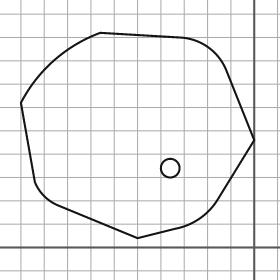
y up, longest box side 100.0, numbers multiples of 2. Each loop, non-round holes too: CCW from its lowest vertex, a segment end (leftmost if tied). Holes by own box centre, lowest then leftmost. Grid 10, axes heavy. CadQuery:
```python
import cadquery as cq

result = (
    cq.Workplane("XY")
    .moveTo(-50.0, 4.0)
    .lineTo(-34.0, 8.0)
    .threePointArc((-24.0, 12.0), (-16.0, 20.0))
    .lineTo(0.0, 46.0)
    .lineTo(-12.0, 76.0)
    .threePointArc((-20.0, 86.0), (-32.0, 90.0))
    .lineTo(-66.0, 92.0)
    .threePointArc((-86.0, 80.0), (-100.0, 62.0))
    .lineTo(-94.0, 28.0)
    .threePointArc((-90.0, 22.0), (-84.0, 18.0))
    .close()
    .moveTo(-36.0, 34.0)
    .circle(4.0)
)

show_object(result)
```